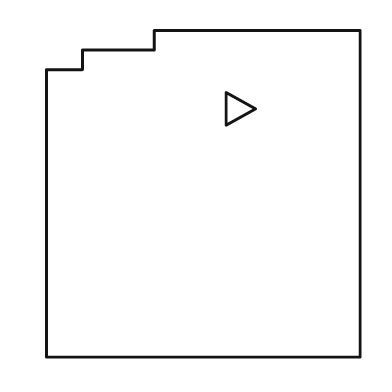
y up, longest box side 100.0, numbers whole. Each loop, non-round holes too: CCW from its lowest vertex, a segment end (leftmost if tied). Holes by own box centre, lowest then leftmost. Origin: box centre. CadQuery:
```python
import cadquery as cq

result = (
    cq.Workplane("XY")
    .moveTo(-48.0, -50.0)
    .lineTo(48.0, -50.0)
    .lineTo(48.0, 50.0)
    .lineTo(-15.0, 50.0)
    .lineTo(-15.0, 44.0)
    .lineTo(-37.0, 44.0)
    .lineTo(-37.0, 38.0)
    .lineTo(-48.0, 38.0)
    .close()
    .moveTo(7.0, 21.0)
    .lineTo(16.0, 26.0)
    .lineTo(7.0, 31.0)
    .close()
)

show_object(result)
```